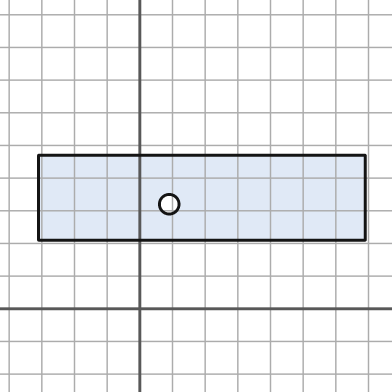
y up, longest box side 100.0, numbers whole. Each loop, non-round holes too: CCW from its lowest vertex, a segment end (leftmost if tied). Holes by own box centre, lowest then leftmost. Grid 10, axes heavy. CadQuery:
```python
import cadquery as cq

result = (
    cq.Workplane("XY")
    .moveTo(-31.0, 21.0)
    .lineTo(69.0, 21.0)
    .lineTo(69.0, 47.0)
    .lineTo(-31.0, 47.0)
    .close()
    .moveTo(9.0, 32.0)
    .circle(3.0)
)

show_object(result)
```